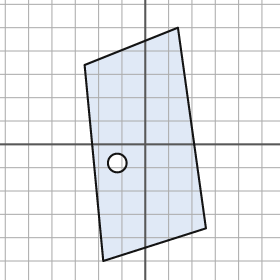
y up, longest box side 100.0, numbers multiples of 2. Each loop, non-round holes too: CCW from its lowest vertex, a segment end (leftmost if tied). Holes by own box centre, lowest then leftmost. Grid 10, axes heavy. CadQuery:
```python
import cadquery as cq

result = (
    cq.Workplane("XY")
    .moveTo(-18.0, -50.0)
    .lineTo(26.0, -36.0)
    .lineTo(14.0, 50.0)
    .lineTo(-26.0, 34.0)
    .close()
    .moveTo(-12.0, -8.0)
    .circle(4.0)
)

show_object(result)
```